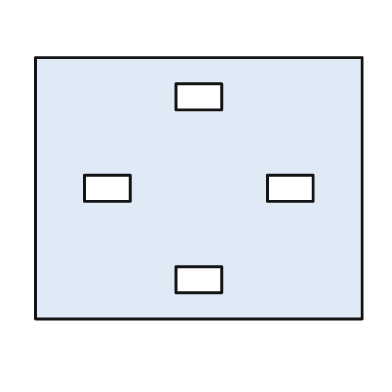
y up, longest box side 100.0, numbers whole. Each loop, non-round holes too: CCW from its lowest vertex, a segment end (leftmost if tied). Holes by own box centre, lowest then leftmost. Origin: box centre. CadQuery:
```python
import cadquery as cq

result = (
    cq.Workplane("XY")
    .moveTo(-50.0, -40.0)
    .lineTo(50.0, -40.0)
    .lineTo(50.0, 40.0)
    .lineTo(-50.0, 40.0)
    .close()
    .moveTo(-7.0, -32.0)
    .lineTo(7.0, -32.0)
    .lineTo(7.0, -24.0)
    .lineTo(-7.0, -24.0)
    .close()
    .moveTo(-35.0, -4.0)
    .lineTo(-21.0, -4.0)
    .lineTo(-21.0, 4.0)
    .lineTo(-35.0, 4.0)
    .close()
    .moveTo(21.0, -4.0)
    .lineTo(35.0, -4.0)
    .lineTo(35.0, 4.0)
    .lineTo(21.0, 4.0)
    .close()
    .moveTo(-7.0, 24.0)
    .lineTo(7.0, 24.0)
    .lineTo(7.0, 32.0)
    .lineTo(-7.0, 32.0)
    .close()
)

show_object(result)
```